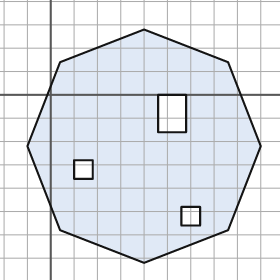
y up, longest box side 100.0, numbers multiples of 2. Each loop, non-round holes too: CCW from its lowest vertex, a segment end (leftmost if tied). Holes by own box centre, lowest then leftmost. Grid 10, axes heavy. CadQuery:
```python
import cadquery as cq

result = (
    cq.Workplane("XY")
    .moveTo(40.0, -72.0)
    .lineTo(76.0, -58.0)
    .lineTo(90.0, -22.0)
    .lineTo(76.0, 14.0)
    .lineTo(40.0, 28.0)
    .lineTo(4.0, 14.0)
    .lineTo(-10.0, -22.0)
    .lineTo(4.0, -58.0)
    .close()
    .moveTo(56.0, -56.0)
    .lineTo(64.0, -56.0)
    .lineTo(64.0, -48.0)
    .lineTo(56.0, -48.0)
    .close()
    .moveTo(10.0, -36.0)
    .lineTo(18.0, -36.0)
    .lineTo(18.0, -28.0)
    .lineTo(10.0, -28.0)
    .close()
    .moveTo(46.0, -16.0)
    .lineTo(58.0, -16.0)
    .lineTo(58.0, 0.0)
    .lineTo(46.0, 0.0)
    .close()
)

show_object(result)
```